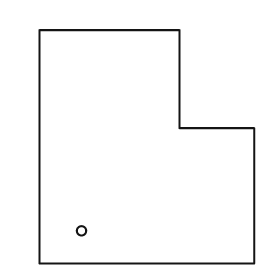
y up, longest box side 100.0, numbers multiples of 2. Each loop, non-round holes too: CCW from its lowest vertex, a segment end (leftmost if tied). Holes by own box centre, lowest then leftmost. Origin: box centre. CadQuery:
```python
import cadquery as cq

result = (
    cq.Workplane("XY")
    .moveTo(-46.0, -50.0)
    .lineTo(46.0, -50.0)
    .lineTo(46.0, 8.0)
    .lineTo(14.0, 8.0)
    .lineTo(14.0, 50.0)
    .lineTo(-46.0, 50.0)
    .close()
    .moveTo(-28.0, -36.0)
    .circle(2.0)
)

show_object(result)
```